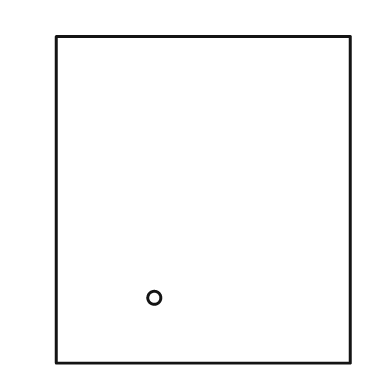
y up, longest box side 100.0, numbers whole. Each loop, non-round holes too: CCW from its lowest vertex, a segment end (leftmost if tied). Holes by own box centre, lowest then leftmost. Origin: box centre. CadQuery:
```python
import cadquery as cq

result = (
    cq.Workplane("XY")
    .moveTo(-45.0, -50.0)
    .lineTo(45.0, -50.0)
    .lineTo(45.0, 50.0)
    .lineTo(-45.0, 50.0)
    .close()
    .moveTo(-15.0, -30.0)
    .circle(2.0)
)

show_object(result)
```